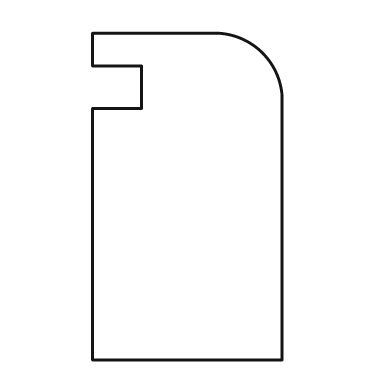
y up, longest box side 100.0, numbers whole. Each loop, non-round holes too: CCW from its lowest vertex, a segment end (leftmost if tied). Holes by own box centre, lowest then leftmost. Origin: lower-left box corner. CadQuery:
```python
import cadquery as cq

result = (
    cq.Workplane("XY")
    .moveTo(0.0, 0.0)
    .lineTo(58.0, 0.0)
    .lineTo(58.0, 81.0)
    .threePointArc((52.0, 94.0), (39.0, 100.0))
    .lineTo(0.0, 100.0)
    .lineTo(0.0, 90.0)
    .lineTo(15.0, 90.0)
    .lineTo(15.0, 77.0)
    .lineTo(0.0, 77.0)
    .close()
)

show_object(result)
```